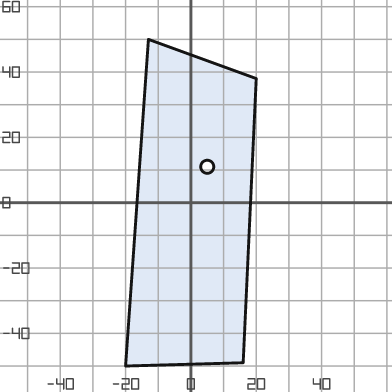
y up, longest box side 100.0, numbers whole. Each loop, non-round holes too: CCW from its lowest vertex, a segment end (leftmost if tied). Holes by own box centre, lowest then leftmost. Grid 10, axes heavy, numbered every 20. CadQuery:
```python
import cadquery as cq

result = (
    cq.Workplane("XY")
    .moveTo(-20.0, -50.0)
    .lineTo(16.0, -49.0)
    .lineTo(20.0, 38.0)
    .lineTo(-13.0, 50.0)
    .close()
    .moveTo(5.0, 11.0)
    .circle(2.0)
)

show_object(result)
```